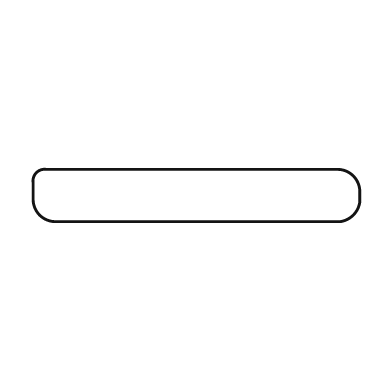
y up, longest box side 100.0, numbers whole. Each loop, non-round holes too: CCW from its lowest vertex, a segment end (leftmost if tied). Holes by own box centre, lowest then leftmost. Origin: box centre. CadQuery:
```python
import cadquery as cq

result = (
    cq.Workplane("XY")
    .moveTo(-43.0, -8.0)
    .lineTo(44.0, -8.0)
    .threePointArc((48.0, -6.0), (50.0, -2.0))
    .lineTo(50.0, 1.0)
    .threePointArc((48.0, 6.0), (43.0, 8.0))
    .lineTo(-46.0, 8.0)
    .threePointArc((-49.0, 7.0), (-50.0, 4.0))
    .lineTo(-50.0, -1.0)
    .threePointArc((-48.0, -6.0), (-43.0, -8.0))
    .close()
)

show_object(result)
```